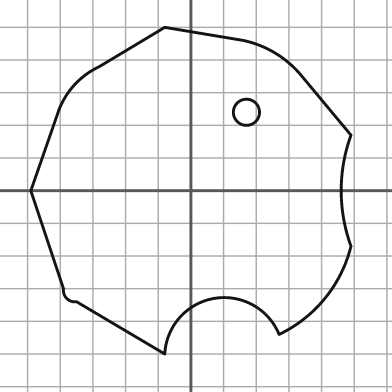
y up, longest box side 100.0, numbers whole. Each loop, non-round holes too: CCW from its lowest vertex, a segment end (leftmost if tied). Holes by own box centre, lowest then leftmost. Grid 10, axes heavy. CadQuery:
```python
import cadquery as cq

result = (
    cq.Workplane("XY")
    .moveTo(-8.0, -50.0)
    .threePointArc((7.0, -33.0), (27.0, -44.0))
    .threePointArc((41.0, -33.0), (49.0, -17.0))
    .threePointArc((46.0, 0.0), (49.0, 17.0))
    .lineTo(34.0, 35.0)
    .threePointArc((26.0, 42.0), (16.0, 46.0))
    .lineTo(-8.0, 50.0)
    .lineTo(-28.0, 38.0)
    .threePointArc((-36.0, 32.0), (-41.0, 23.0))
    .lineTo(-49.0, 0.0)
    .lineTo(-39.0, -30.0)
    .threePointArc((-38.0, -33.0), (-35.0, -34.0))
    .close()
    .moveTo(17.0, 24.0)
    .circle(4.0)
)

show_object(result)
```